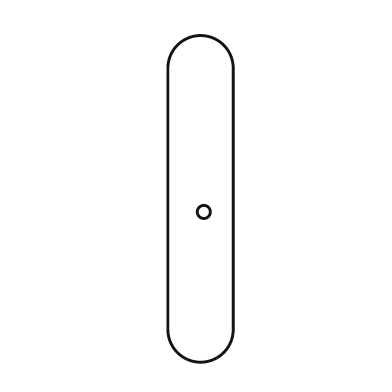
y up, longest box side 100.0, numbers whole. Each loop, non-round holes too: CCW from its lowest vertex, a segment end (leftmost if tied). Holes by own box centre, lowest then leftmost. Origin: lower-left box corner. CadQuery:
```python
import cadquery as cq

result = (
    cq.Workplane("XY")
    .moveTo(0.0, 10.0)
    .threePointArc((10.0, 0.0), (20.0, 10.0))
    .lineTo(20.0, 90.0)
    .threePointArc((10.0, 100.0), (0.0, 90.0))
    .close()
    .moveTo(11.0, 46.0)
    .circle(2.0)
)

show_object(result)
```